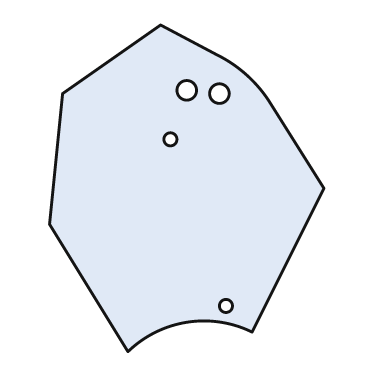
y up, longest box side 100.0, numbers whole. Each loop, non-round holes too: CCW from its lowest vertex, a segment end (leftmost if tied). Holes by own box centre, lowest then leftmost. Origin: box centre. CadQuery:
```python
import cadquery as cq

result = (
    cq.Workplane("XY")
    .moveTo(-18.0, -50.0)
    .threePointArc((0.0, -41.0), (20.0, -44.0))
    .lineTo(42.0, 0.0)
    .lineTo(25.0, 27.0)
    .threePointArc((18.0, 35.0), (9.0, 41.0))
    .lineTo(-8.0, 50.0)
    .lineTo(-38.0, 29.0)
    .lineTo(-42.0, -11.0)
    .close()
    .moveTo(12.0, -36.0)
    .circle(2.0)
    .moveTo(-5.0, 15.0)
    .circle(2.0)
    .moveTo(10.0, 29.0)
    .circle(3.0)
    .moveTo(0.0, 30.0)
    .circle(3.0)
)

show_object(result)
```